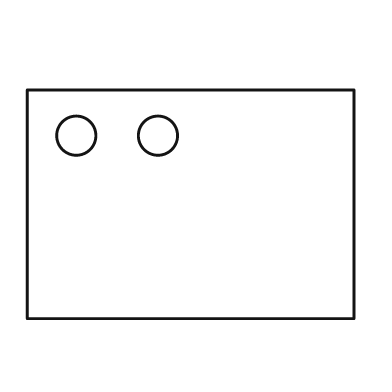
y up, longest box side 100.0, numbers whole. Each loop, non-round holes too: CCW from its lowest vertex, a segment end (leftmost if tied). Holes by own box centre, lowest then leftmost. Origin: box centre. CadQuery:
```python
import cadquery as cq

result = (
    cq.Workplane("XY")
    .moveTo(-50.0, -35.0)
    .lineTo(50.0, -35.0)
    .lineTo(50.0, 35.0)
    .lineTo(-50.0, 35.0)
    .close()
    .moveTo(-35.0, 21.0)
    .circle(6.0)
    .moveTo(-10.0, 21.0)
    .circle(6.0)
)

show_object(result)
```